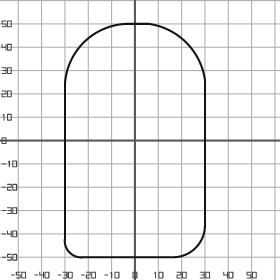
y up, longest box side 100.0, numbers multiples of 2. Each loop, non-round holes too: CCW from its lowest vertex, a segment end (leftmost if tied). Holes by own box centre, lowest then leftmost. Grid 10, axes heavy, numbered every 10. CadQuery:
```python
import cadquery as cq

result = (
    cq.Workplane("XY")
    .moveTo(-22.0, -50.0)
    .lineTo(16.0, -50.0)
    .threePointArc((26.0, -46.0), (30.0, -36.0))
    .lineTo(30.0, 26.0)
    .threePointArc((22.0, 42.0), (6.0, 50.0))
    .lineTo(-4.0, 50.0)
    .threePointArc((-22.0, 42.0), (-30.0, 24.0))
    .lineTo(-30.0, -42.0)
    .threePointArc((-28.0, -48.0), (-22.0, -50.0))
    .close()
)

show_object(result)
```